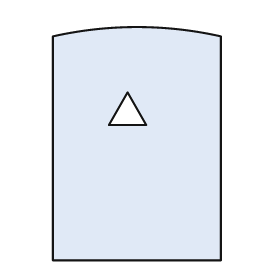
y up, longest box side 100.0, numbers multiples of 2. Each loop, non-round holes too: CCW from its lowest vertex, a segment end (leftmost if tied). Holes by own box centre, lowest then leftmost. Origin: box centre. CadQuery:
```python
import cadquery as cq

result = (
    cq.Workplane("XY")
    .moveTo(-36.0, -50.0)
    .lineTo(36.0, -50.0)
    .lineTo(36.0, 46.0)
    .threePointArc((0.0, 50.0), (-36.0, 46.0))
    .close()
    .moveTo(-12.0, 8.0)
    .lineTo(4.0, 8.0)
    .lineTo(-4.0, 22.0)
    .close()
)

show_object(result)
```